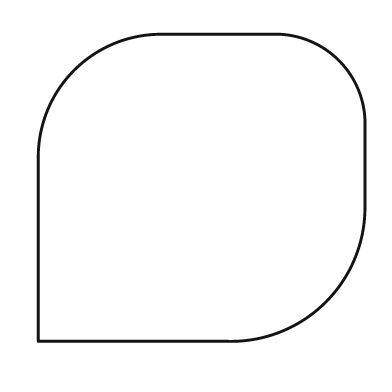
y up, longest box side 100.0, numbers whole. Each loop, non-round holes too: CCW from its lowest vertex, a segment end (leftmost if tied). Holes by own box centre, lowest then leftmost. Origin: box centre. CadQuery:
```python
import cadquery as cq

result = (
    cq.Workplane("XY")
    .moveTo(-50.0, -47.0)
    .lineTo(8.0, -47.0)
    .threePointArc((38.0, -35.0), (50.0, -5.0))
    .lineTo(50.0, 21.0)
    .threePointArc((42.0, 39.0), (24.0, 47.0))
    .lineTo(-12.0, 47.0)
    .threePointArc((-39.0, 36.0), (-50.0, 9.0))
    .close()
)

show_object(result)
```